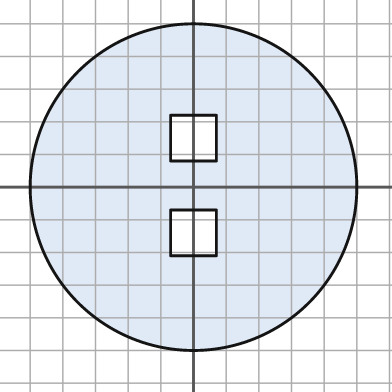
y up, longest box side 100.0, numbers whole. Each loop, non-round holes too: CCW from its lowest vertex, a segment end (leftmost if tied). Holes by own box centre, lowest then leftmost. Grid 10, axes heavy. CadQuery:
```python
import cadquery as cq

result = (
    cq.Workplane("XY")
    .moveTo(0.0, 0.0)
    .circle(50.0)
    .moveTo(-7.0, -21.0)
    .lineTo(7.0, -21.0)
    .lineTo(7.0, -7.0)
    .lineTo(-7.0, -7.0)
    .close()
    .moveTo(-7.0, 8.0)
    .lineTo(7.0, 8.0)
    .lineTo(7.0, 22.0)
    .lineTo(-7.0, 22.0)
    .close()
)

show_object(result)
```